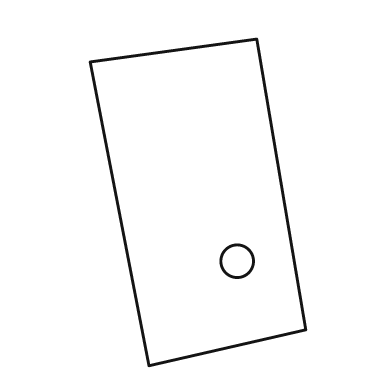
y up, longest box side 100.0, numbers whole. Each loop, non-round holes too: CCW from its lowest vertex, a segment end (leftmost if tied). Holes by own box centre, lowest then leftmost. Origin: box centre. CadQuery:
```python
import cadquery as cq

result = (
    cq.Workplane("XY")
    .moveTo(-15.0, -50.0)
    .lineTo(33.0, -39.0)
    .lineTo(18.0, 50.0)
    .lineTo(-33.0, 43.0)
    .close()
    .moveTo(12.0, -18.0)
    .circle(5.0)
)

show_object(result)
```